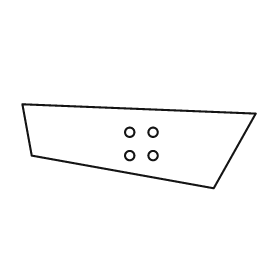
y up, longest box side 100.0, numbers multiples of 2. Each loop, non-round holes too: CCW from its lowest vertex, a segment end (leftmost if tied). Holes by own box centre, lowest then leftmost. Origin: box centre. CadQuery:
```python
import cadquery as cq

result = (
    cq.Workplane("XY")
    .moveTo(32.0, -18.0)
    .lineTo(50.0, 14.0)
    .lineTo(-50.0, 18.0)
    .lineTo(-46.0, -4.0)
    .close()
    .moveTo(-4.0, -4.0)
    .circle(2.0)
    .moveTo(6.0, -4.0)
    .circle(2.0)
    .moveTo(-4.0, 6.0)
    .circle(2.0)
    .moveTo(6.0, 6.0)
    .circle(2.0)
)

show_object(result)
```